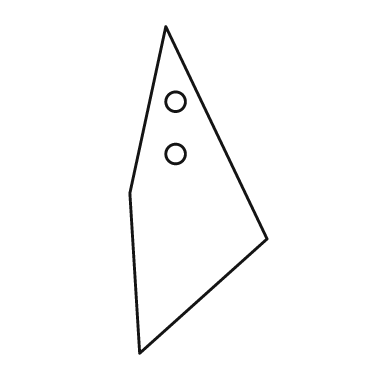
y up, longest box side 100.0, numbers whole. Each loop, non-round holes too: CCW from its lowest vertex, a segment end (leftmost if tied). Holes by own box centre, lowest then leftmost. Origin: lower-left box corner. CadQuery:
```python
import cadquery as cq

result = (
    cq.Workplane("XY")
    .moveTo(3.0, 0.0)
    .lineTo(42.0, 35.0)
    .lineTo(11.0, 100.0)
    .lineTo(0.0, 49.0)
    .close()
    .moveTo(14.0, 61.0)
    .circle(3.0)
    .moveTo(14.0, 77.0)
    .circle(3.0)
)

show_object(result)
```